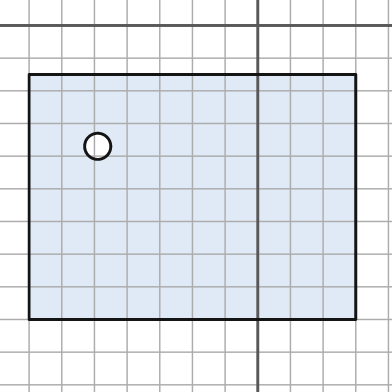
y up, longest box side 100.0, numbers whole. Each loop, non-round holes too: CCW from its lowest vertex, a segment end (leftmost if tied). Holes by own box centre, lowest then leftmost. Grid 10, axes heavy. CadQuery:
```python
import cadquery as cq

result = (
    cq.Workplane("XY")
    .moveTo(-70.0, -90.0)
    .lineTo(30.0, -90.0)
    .lineTo(30.0, -15.0)
    .lineTo(-70.0, -15.0)
    .close()
    .moveTo(-49.0, -37.0)
    .circle(4.0)
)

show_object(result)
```